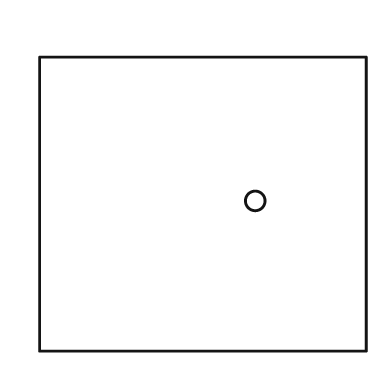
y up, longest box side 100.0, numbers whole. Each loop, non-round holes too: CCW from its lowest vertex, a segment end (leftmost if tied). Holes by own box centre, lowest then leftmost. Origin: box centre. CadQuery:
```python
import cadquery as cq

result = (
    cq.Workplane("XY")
    .moveTo(-50.0, -45.0)
    .lineTo(50.0, -45.0)
    .lineTo(50.0, 45.0)
    .lineTo(-50.0, 45.0)
    .close()
    .moveTo(16.0, 1.0)
    .circle(3.0)
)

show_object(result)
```